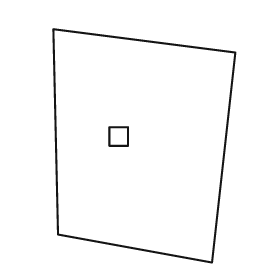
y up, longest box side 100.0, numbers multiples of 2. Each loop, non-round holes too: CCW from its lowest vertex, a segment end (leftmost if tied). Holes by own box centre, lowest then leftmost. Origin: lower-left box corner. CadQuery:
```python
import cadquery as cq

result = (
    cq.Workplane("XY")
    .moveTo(68.0, 0.0)
    .lineTo(78.0, 90.0)
    .lineTo(0.0, 100.0)
    .lineTo(2.0, 12.0)
    .close()
    .moveTo(24.0, 50.0)
    .lineTo(32.0, 50.0)
    .lineTo(32.0, 58.0)
    .lineTo(24.0, 58.0)
    .close()
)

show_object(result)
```